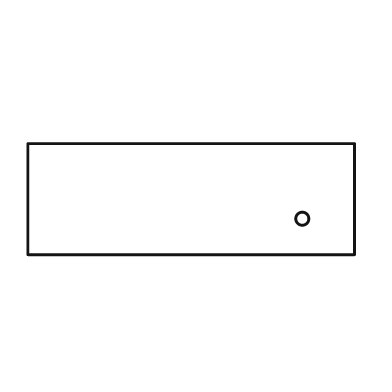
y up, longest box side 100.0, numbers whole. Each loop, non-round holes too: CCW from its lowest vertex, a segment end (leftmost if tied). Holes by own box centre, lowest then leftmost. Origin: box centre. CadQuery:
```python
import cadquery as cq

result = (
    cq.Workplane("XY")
    .moveTo(-50.0, -17.0)
    .lineTo(50.0, -17.0)
    .lineTo(50.0, 17.0)
    .lineTo(-50.0, 17.0)
    .close()
    .moveTo(34.0, -6.0)
    .circle(2.0)
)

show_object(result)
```